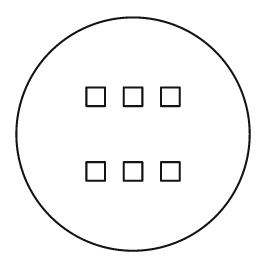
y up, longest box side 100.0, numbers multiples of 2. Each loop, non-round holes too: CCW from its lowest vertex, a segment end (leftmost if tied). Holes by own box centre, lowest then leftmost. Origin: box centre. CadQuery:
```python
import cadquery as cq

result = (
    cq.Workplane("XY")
    .moveTo(0.0, 0.0)
    .circle(50.0)
    .moveTo(-20.0, -20.0)
    .lineTo(-12.0, -20.0)
    .lineTo(-12.0, -12.0)
    .lineTo(-20.0, -12.0)
    .close()
    .moveTo(-4.0, -20.0)
    .lineTo(4.0, -20.0)
    .lineTo(4.0, -12.0)
    .lineTo(-4.0, -12.0)
    .close()
    .moveTo(12.0, -20.0)
    .lineTo(20.0, -20.0)
    .lineTo(20.0, -12.0)
    .lineTo(12.0, -12.0)
    .close()
    .moveTo(-20.0, 12.0)
    .lineTo(-12.0, 12.0)
    .lineTo(-12.0, 20.0)
    .lineTo(-20.0, 20.0)
    .close()
    .moveTo(-4.0, 12.0)
    .lineTo(4.0, 12.0)
    .lineTo(4.0, 20.0)
    .lineTo(-4.0, 20.0)
    .close()
    .moveTo(12.0, 12.0)
    .lineTo(20.0, 12.0)
    .lineTo(20.0, 20.0)
    .lineTo(12.0, 20.0)
    .close()
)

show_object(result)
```